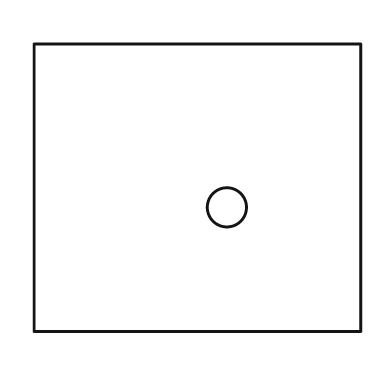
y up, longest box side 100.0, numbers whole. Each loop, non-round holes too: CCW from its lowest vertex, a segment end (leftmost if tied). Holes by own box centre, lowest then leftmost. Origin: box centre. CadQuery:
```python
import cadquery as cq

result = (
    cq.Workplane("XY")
    .moveTo(-50.0, -44.0)
    .lineTo(50.0, -44.0)
    .lineTo(50.0, 44.0)
    .lineTo(-50.0, 44.0)
    .close()
    .moveTo(9.0, -6.0)
    .circle(6.0)
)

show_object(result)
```